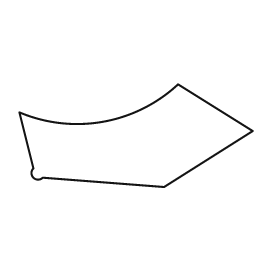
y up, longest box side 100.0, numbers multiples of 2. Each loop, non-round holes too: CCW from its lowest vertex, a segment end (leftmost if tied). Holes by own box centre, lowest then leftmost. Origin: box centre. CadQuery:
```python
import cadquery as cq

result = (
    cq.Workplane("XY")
    .moveTo(12.0, -22.0)
    .lineTo(50.0, 2.0)
    .lineTo(18.0, 22.0)
    .threePointArc((-14.0, 6.0), (-50.0, 10.0))
    .lineTo(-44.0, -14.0)
    .threePointArc((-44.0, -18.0), (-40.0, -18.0))
    .close()
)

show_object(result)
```